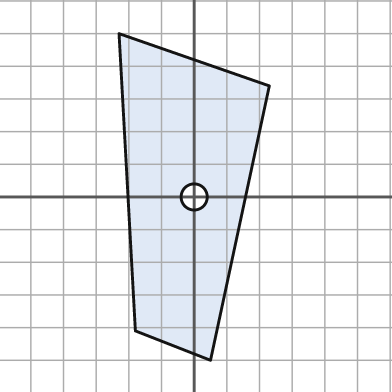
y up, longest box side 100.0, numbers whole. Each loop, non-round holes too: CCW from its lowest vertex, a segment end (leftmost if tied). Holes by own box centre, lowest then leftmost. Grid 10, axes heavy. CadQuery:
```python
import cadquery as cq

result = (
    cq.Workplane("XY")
    .moveTo(5.0, -50.0)
    .lineTo(23.0, 34.0)
    .lineTo(-23.0, 50.0)
    .lineTo(-18.0, -41.0)
    .close()
    .moveTo(0.0, 0.0)
    .circle(4.0)
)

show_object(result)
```